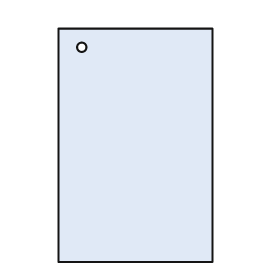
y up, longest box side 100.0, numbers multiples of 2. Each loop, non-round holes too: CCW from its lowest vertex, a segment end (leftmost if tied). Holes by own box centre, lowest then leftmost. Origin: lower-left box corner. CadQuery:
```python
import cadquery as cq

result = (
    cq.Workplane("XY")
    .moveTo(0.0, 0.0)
    .lineTo(66.0, 0.0)
    .lineTo(66.0, 100.0)
    .lineTo(0.0, 100.0)
    .close()
    .moveTo(10.0, 92.0)
    .circle(2.0)
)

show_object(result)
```